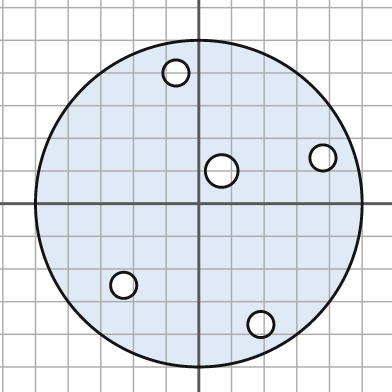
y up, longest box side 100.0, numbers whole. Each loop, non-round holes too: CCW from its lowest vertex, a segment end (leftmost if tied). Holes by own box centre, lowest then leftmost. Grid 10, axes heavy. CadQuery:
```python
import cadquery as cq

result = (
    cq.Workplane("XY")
    .moveTo(0.0, 0.0)
    .circle(50.0)
    .moveTo(19.0, -37.0)
    .circle(4.0)
    .moveTo(-23.0, -25.0)
    .circle(4.0)
    .moveTo(7.0, 10.0)
    .circle(5.0)
    .moveTo(38.0, 14.0)
    .circle(4.0)
    .moveTo(-7.0, 40.0)
    .circle(4.0)
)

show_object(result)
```